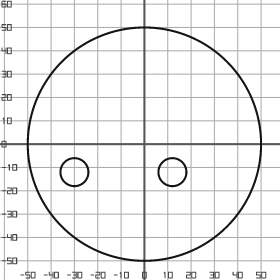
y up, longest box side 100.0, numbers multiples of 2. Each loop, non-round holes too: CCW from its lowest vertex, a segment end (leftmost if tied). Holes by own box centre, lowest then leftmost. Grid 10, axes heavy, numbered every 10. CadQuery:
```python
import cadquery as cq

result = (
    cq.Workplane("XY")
    .moveTo(0.0, 0.0)
    .circle(50.0)
    .moveTo(-30.0, -12.0)
    .circle(6.0)
    .moveTo(12.0, -12.0)
    .circle(6.0)
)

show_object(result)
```